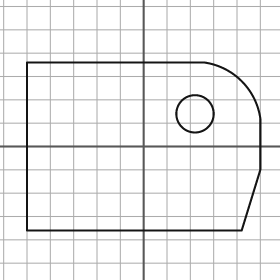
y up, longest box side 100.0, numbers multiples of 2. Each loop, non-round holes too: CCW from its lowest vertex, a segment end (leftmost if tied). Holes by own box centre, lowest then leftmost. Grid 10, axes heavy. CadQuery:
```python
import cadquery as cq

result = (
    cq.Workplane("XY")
    .moveTo(-50.0, -36.0)
    .lineTo(42.0, -36.0)
    .lineTo(50.0, -10.0)
    .lineTo(50.0, 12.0)
    .threePointArc((42.0, 28.0), (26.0, 36.0))
    .lineTo(-50.0, 36.0)
    .close()
    .moveTo(22.0, 14.0)
    .circle(8.0)
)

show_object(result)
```